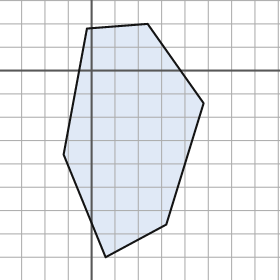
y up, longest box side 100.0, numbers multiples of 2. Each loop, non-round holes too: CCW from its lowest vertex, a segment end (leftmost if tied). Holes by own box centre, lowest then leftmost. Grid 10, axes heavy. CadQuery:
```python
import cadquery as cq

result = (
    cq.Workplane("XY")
    .moveTo(6.0, -80.0)
    .lineTo(32.0, -66.0)
    .lineTo(48.0, -14.0)
    .lineTo(24.0, 20.0)
    .lineTo(-2.0, 18.0)
    .lineTo(-12.0, -36.0)
    .close()
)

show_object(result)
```